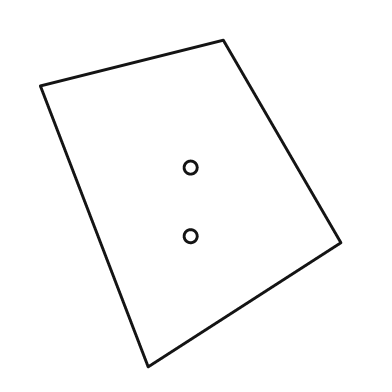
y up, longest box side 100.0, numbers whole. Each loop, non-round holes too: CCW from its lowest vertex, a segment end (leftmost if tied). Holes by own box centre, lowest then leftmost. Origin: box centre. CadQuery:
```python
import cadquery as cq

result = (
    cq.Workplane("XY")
    .moveTo(-13.0, -50.0)
    .lineTo(46.0, -12.0)
    .lineTo(10.0, 50.0)
    .lineTo(-46.0, 36.0)
    .close()
    .moveTo(0.0, -10.0)
    .circle(2.0)
    .moveTo(0.0, 11.0)
    .circle(2.0)
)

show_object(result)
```